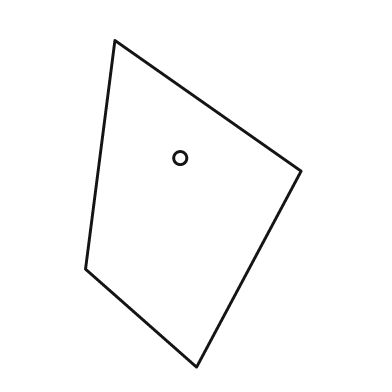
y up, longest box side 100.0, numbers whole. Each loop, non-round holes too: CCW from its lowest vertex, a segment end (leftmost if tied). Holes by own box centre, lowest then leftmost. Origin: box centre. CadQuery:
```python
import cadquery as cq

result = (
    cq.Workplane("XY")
    .moveTo(1.0, -50.0)
    .lineTo(33.0, 10.0)
    .lineTo(-24.0, 50.0)
    .lineTo(-33.0, -20.0)
    .close()
    .moveTo(-4.0, 14.0)
    .circle(2.0)
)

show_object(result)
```